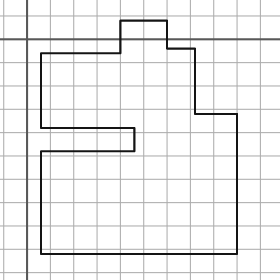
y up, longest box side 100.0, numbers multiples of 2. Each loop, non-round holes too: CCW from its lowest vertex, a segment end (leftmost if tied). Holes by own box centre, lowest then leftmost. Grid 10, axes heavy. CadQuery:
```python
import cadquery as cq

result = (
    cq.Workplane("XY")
    .moveTo(6.0, -92.0)
    .lineTo(90.0, -92.0)
    .lineTo(90.0, -32.0)
    .lineTo(72.0, -32.0)
    .lineTo(72.0, -4.0)
    .lineTo(60.0, -4.0)
    .lineTo(60.0, 8.0)
    .lineTo(40.0, 8.0)
    .lineTo(40.0, -6.0)
    .lineTo(6.0, -6.0)
    .lineTo(6.0, -38.0)
    .lineTo(46.0, -38.0)
    .lineTo(46.0, -48.0)
    .lineTo(6.0, -48.0)
    .close()
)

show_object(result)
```